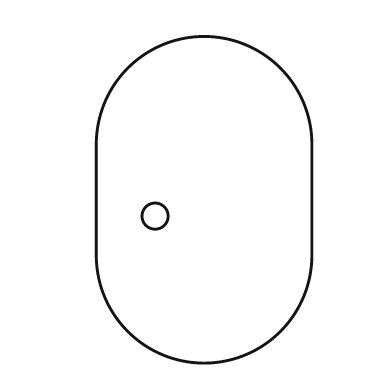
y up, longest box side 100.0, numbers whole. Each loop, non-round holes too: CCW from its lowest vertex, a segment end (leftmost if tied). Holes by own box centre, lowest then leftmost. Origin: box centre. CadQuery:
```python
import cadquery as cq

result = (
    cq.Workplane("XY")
    .moveTo(-33.0, -17.0)
    .threePointArc((0.0, -50.0), (33.0, -17.0))
    .lineTo(33.0, 17.0)
    .threePointArc((0.0, 50.0), (-33.0, 17.0))
    .close()
    .moveTo(-15.0, -5.0)
    .circle(4.0)
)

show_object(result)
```